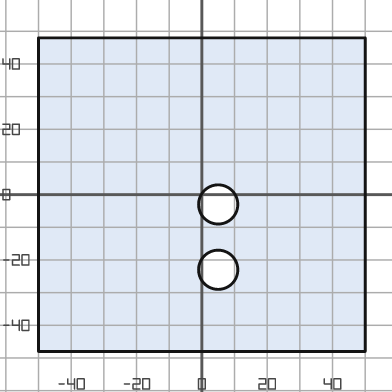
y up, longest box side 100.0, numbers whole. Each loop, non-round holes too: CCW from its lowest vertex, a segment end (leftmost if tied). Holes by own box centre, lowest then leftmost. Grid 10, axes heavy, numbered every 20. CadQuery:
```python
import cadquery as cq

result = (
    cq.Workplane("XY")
    .moveTo(-50.0, -48.0)
    .lineTo(50.0, -48.0)
    .lineTo(50.0, 48.0)
    .lineTo(-50.0, 48.0)
    .close()
    .moveTo(5.0, -23.0)
    .circle(6.0)
    .moveTo(5.0, -3.0)
    .circle(6.0)
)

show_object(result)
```